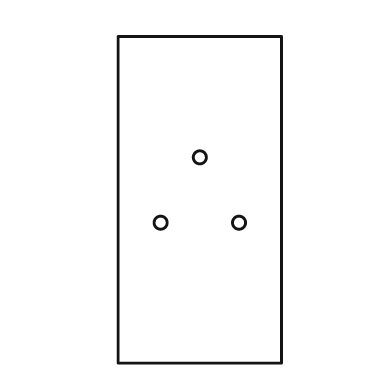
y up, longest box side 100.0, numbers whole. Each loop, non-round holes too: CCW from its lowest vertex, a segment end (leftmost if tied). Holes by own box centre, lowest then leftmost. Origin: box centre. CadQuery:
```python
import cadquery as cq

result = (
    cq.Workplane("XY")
    .moveTo(-25.0, -50.0)
    .lineTo(25.0, -50.0)
    .lineTo(25.0, 50.0)
    .lineTo(-25.0, 50.0)
    .close()
    .moveTo(-12.0, -7.0)
    .circle(2.0)
    .moveTo(12.0, -7.0)
    .circle(2.0)
    .moveTo(0.0, 13.0)
    .circle(2.0)
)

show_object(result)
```